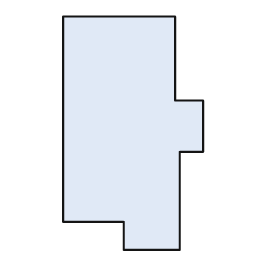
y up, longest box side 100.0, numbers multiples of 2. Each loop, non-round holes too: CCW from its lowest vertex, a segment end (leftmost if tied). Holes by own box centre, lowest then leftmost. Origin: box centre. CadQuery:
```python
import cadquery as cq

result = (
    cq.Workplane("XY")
    .moveTo(-4.0, -50.0)
    .lineTo(20.0, -50.0)
    .lineTo(20.0, -8.0)
    .lineTo(30.0, -8.0)
    .lineTo(30.0, 14.0)
    .lineTo(18.0, 14.0)
    .lineTo(18.0, 50.0)
    .lineTo(-30.0, 50.0)
    .lineTo(-30.0, -38.0)
    .lineTo(-4.0, -38.0)
    .close()
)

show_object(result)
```